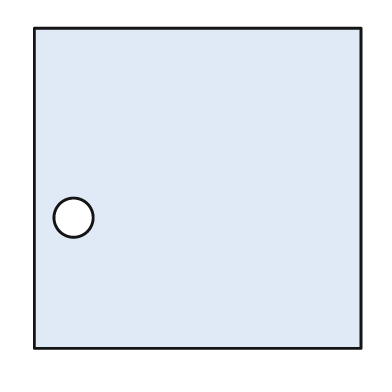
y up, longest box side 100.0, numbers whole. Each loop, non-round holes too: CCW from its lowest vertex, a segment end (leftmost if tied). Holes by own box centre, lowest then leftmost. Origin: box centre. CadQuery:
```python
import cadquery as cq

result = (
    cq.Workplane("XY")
    .moveTo(-50.0, -49.0)
    .lineTo(50.0, -49.0)
    .lineTo(50.0, 49.0)
    .lineTo(-50.0, 49.0)
    .close()
    .moveTo(-38.0, -9.0)
    .circle(6.0)
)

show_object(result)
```